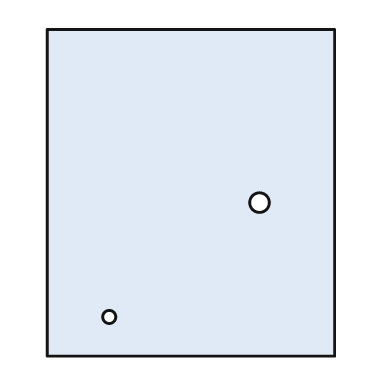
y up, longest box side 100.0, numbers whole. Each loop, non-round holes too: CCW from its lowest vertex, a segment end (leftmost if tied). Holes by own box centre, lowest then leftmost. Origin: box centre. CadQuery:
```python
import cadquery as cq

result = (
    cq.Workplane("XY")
    .moveTo(-44.0, -50.0)
    .lineTo(44.0, -50.0)
    .lineTo(44.0, 50.0)
    .lineTo(-44.0, 50.0)
    .close()
    .moveTo(-25.0, -38.0)
    .circle(2.0)
    .moveTo(21.0, -3.0)
    .circle(3.0)
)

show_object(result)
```